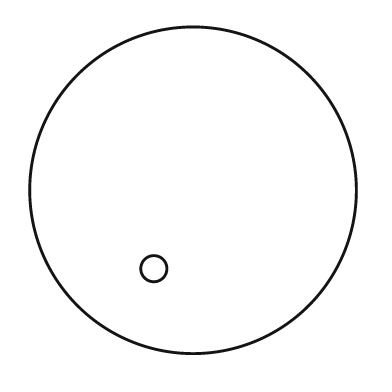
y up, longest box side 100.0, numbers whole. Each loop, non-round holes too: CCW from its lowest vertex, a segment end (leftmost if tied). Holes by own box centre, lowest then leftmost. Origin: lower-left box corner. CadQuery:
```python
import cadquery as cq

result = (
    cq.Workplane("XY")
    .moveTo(50.0, 50.0)
    .circle(50.0)
    .moveTo(38.0, 26.0)
    .circle(4.0)
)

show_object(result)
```